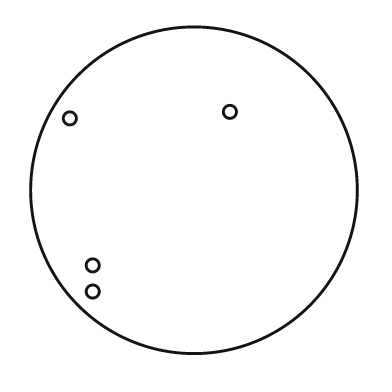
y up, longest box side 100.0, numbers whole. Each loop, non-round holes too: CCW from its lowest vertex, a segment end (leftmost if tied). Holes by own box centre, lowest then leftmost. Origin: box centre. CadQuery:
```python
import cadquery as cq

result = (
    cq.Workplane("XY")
    .moveTo(0.0, 0.0)
    .circle(50.0)
    .moveTo(-31.0, -31.0)
    .circle(2.0)
    .moveTo(-31.0, -23.0)
    .circle(2.0)
    .moveTo(-38.0, 22.0)
    .circle(2.0)
    .moveTo(11.0, 24.0)
    .circle(2.0)
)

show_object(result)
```